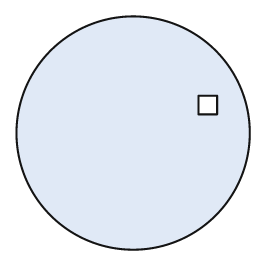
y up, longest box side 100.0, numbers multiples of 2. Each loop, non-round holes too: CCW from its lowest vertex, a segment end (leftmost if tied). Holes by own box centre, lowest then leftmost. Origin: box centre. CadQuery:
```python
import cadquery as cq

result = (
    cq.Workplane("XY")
    .moveTo(0.0, 0.0)
    .circle(50.0)
    .moveTo(28.0, 8.0)
    .lineTo(36.0, 8.0)
    .lineTo(36.0, 16.0)
    .lineTo(28.0, 16.0)
    .close()
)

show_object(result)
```